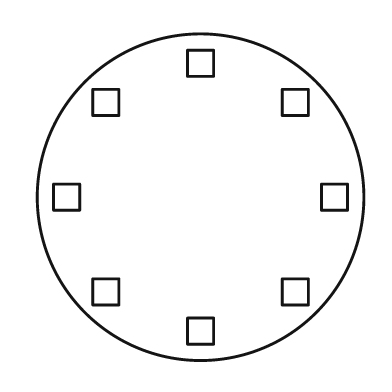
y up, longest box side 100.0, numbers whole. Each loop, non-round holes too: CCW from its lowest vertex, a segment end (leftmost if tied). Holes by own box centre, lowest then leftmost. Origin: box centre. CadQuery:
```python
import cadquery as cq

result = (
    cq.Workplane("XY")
    .moveTo(0.0, 0.0)
    .circle(50.0)
    .moveTo(-4.0, -45.0)
    .lineTo(4.0, -45.0)
    .lineTo(4.0, -37.0)
    .lineTo(-4.0, -37.0)
    .close()
    .moveTo(-33.0, -33.0)
    .lineTo(-25.0, -33.0)
    .lineTo(-25.0, -25.0)
    .lineTo(-33.0, -25.0)
    .close()
    .moveTo(25.0, -33.0)
    .lineTo(33.0, -33.0)
    .lineTo(33.0, -25.0)
    .lineTo(25.0, -25.0)
    .close()
    .moveTo(-45.0, -4.0)
    .lineTo(-37.0, -4.0)
    .lineTo(-37.0, 4.0)
    .lineTo(-45.0, 4.0)
    .close()
    .moveTo(37.0, -4.0)
    .lineTo(45.0, -4.0)
    .lineTo(45.0, 4.0)
    .lineTo(37.0, 4.0)
    .close()
    .moveTo(-33.0, 25.0)
    .lineTo(-25.0, 25.0)
    .lineTo(-25.0, 33.0)
    .lineTo(-33.0, 33.0)
    .close()
    .moveTo(25.0, 25.0)
    .lineTo(33.0, 25.0)
    .lineTo(33.0, 33.0)
    .lineTo(25.0, 33.0)
    .close()
    .moveTo(-4.0, 37.0)
    .lineTo(4.0, 37.0)
    .lineTo(4.0, 45.0)
    .lineTo(-4.0, 45.0)
    .close()
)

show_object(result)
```